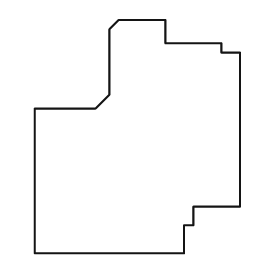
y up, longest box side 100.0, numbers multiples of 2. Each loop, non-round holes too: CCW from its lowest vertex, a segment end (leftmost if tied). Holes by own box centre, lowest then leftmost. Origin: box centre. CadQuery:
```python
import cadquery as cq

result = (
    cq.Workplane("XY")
    .moveTo(-44.0, -50.0)
    .lineTo(20.0, -50.0)
    .lineTo(20.0, -38.0)
    .lineTo(24.0, -38.0)
    .lineTo(24.0, -30.0)
    .lineTo(44.0, -30.0)
    .lineTo(44.0, 36.0)
    .lineTo(36.0, 36.0)
    .lineTo(36.0, 40.0)
    .lineTo(12.0, 40.0)
    .lineTo(12.0, 50.0)
    .lineTo(-8.0, 50.0)
    .lineTo(-12.0, 46.0)
    .lineTo(-12.0, 18.0)
    .lineTo(-18.0, 12.0)
    .lineTo(-44.0, 12.0)
    .close()
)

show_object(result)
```